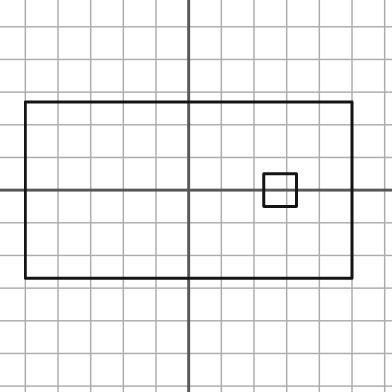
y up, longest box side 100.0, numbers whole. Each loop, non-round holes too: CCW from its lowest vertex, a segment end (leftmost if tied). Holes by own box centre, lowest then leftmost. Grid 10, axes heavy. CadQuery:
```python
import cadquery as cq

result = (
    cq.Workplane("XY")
    .moveTo(-50.0, -27.0)
    .lineTo(50.0, -27.0)
    .lineTo(50.0, 27.0)
    .lineTo(-50.0, 27.0)
    .close()
    .moveTo(23.0, -5.0)
    .lineTo(33.0, -5.0)
    .lineTo(33.0, 5.0)
    .lineTo(23.0, 5.0)
    .close()
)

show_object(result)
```